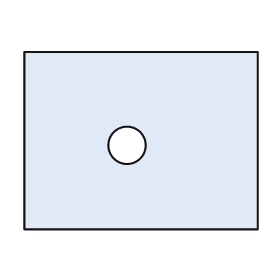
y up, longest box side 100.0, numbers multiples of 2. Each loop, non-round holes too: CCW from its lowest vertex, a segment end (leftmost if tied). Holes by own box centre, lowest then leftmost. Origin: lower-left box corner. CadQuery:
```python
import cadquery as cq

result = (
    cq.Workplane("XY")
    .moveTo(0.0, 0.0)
    .lineTo(100.0, 0.0)
    .lineTo(100.0, 76.0)
    .lineTo(0.0, 76.0)
    .close()
    .moveTo(44.0, 36.0)
    .circle(8.0)
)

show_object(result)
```